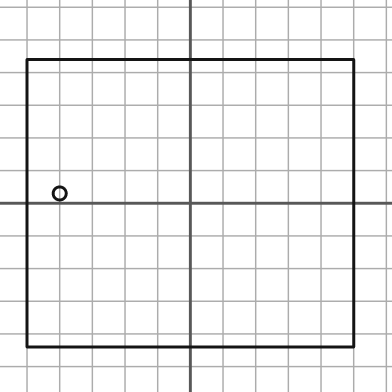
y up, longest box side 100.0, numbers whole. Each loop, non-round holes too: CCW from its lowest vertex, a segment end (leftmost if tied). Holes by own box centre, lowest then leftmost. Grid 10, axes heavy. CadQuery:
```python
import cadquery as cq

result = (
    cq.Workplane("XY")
    .moveTo(-50.0, -44.0)
    .lineTo(50.0, -44.0)
    .lineTo(50.0, 44.0)
    .lineTo(-50.0, 44.0)
    .close()
    .moveTo(-40.0, 3.0)
    .circle(2.0)
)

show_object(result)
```